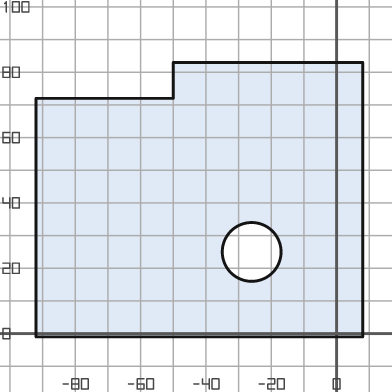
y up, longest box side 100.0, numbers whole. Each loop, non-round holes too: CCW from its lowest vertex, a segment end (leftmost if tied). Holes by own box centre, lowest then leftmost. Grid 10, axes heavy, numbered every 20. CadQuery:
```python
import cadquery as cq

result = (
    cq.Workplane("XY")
    .moveTo(-92.0, -1.0)
    .lineTo(8.0, -1.0)
    .lineTo(8.0, 83.0)
    .lineTo(-50.0, 83.0)
    .lineTo(-50.0, 72.0)
    .lineTo(-92.0, 72.0)
    .close()
    .moveTo(-26.0, 25.0)
    .circle(9.0)
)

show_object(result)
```